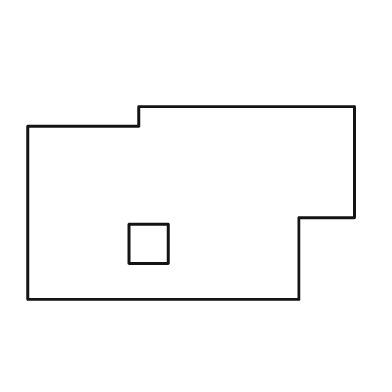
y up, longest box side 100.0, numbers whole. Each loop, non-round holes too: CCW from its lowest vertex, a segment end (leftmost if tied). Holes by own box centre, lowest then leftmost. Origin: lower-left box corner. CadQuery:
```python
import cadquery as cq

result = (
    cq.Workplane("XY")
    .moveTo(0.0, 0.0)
    .lineTo(83.0, 0.0)
    .lineTo(83.0, 25.0)
    .lineTo(100.0, 25.0)
    .lineTo(100.0, 59.0)
    .lineTo(34.0, 59.0)
    .lineTo(34.0, 53.0)
    .lineTo(0.0, 53.0)
    .close()
    .moveTo(31.0, 11.0)
    .lineTo(43.0, 11.0)
    .lineTo(43.0, 23.0)
    .lineTo(31.0, 23.0)
    .close()
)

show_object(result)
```